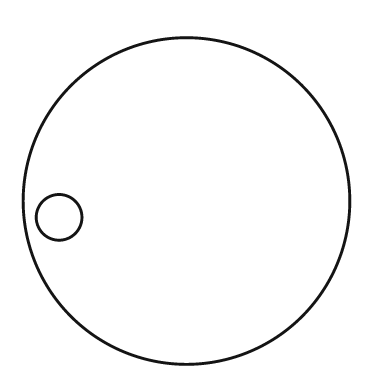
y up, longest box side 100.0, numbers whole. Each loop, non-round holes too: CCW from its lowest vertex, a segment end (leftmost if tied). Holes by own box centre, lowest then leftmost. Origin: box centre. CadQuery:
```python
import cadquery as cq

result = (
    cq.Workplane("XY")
    .moveTo(0.0, 0.0)
    .circle(50.0)
    .moveTo(-39.0, -5.0)
    .circle(7.0)
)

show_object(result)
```